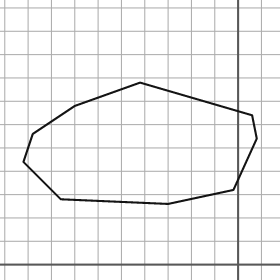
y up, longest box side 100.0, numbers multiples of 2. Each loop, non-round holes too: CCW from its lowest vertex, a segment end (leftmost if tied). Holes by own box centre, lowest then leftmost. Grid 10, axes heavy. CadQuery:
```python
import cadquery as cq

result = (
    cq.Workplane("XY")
    .moveTo(-30.0, 26.0)
    .lineTo(-2.0, 32.0)
    .lineTo(8.0, 54.0)
    .lineTo(6.0, 64.0)
    .lineTo(-42.0, 78.0)
    .lineTo(-70.0, 68.0)
    .lineTo(-88.0, 56.0)
    .lineTo(-92.0, 44.0)
    .lineTo(-76.0, 28.0)
    .close()
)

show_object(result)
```